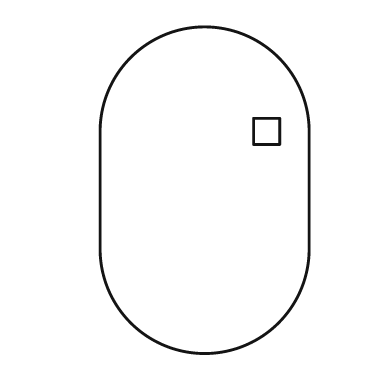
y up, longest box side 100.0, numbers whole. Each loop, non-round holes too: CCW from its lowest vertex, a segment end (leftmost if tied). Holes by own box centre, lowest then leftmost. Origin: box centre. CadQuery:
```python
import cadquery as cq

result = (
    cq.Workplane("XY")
    .moveTo(-32.0, -18.0)
    .threePointArc((0.0, -50.0), (32.0, -18.0))
    .lineTo(32.0, 18.0)
    .threePointArc((0.0, 50.0), (-32.0, 18.0))
    .close()
    .moveTo(15.0, 14.0)
    .lineTo(23.0, 14.0)
    .lineTo(23.0, 22.0)
    .lineTo(15.0, 22.0)
    .close()
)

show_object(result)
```